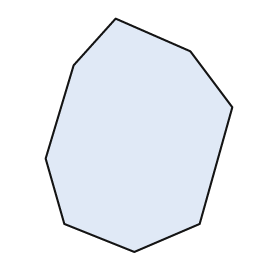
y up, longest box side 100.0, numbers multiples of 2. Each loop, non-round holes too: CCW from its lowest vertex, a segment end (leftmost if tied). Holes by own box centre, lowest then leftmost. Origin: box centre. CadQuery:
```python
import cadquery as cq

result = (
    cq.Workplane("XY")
    .moveTo(-2.0, -50.0)
    .lineTo(26.0, -38.0)
    .lineTo(40.0, 12.0)
    .lineTo(22.0, 36.0)
    .lineTo(-10.0, 50.0)
    .lineTo(-28.0, 30.0)
    .lineTo(-40.0, -10.0)
    .lineTo(-32.0, -38.0)
    .close()
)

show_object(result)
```